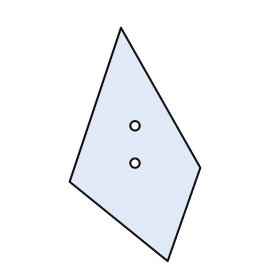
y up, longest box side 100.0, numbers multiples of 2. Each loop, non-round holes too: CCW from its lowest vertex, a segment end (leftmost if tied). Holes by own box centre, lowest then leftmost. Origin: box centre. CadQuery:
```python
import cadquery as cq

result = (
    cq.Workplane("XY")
    .moveTo(14.0, -50.0)
    .lineTo(28.0, -10.0)
    .lineTo(-6.0, 50.0)
    .lineTo(-28.0, -16.0)
    .close()
    .moveTo(0.0, -8.0)
    .circle(2.0)
    .moveTo(0.0, 8.0)
    .circle(2.0)
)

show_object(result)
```